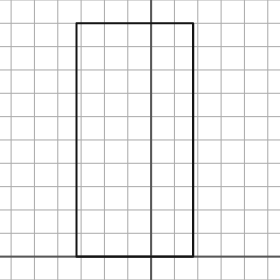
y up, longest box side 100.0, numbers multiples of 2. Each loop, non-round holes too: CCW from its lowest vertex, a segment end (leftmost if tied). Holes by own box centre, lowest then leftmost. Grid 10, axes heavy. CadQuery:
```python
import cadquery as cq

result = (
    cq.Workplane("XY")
    .moveTo(-32.0, 0.0)
    .lineTo(18.0, 0.0)
    .lineTo(18.0, 100.0)
    .lineTo(-32.0, 100.0)
    .close()
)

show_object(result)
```